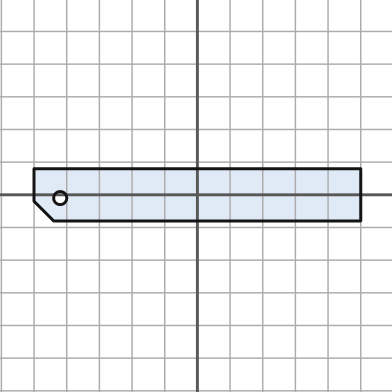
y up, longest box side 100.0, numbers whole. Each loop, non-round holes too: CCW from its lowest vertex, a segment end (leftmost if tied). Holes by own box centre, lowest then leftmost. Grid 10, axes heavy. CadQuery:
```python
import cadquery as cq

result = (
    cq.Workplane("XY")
    .moveTo(-44.0, -8.0)
    .lineTo(50.0, -8.0)
    .lineTo(50.0, 8.0)
    .lineTo(-50.0, 8.0)
    .lineTo(-50.0, -2.0)
    .close()
    .moveTo(-42.0, -1.0)
    .circle(2.0)
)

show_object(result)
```